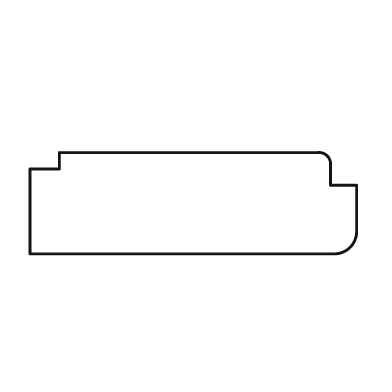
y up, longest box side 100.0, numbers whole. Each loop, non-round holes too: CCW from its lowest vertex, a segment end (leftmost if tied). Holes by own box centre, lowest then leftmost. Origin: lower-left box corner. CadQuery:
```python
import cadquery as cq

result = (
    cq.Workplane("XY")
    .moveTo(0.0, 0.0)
    .lineTo(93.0, 0.0)
    .threePointArc((98.0, 2.0), (100.0, 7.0))
    .lineTo(100.0, 21.0)
    .lineTo(92.0, 21.0)
    .lineTo(92.0, 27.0)
    .threePointArc((91.0, 30.0), (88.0, 31.0))
    .lineTo(9.0, 31.0)
    .lineTo(9.0, 26.0)
    .lineTo(0.0, 26.0)
    .close()
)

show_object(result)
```